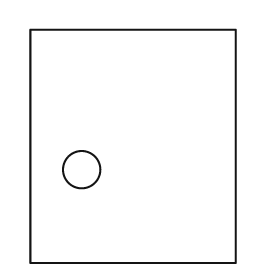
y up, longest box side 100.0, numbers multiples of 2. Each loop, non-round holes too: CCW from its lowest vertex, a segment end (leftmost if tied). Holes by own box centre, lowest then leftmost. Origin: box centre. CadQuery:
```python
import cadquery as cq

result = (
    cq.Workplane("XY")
    .moveTo(-44.0, -50.0)
    .lineTo(44.0, -50.0)
    .lineTo(44.0, 50.0)
    .lineTo(-44.0, 50.0)
    .close()
    .moveTo(-22.0, -10.0)
    .circle(8.0)
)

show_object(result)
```